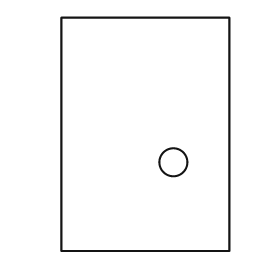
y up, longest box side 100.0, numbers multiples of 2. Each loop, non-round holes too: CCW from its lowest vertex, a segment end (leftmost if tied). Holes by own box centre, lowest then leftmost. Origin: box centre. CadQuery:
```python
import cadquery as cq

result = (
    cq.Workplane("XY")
    .moveTo(-36.0, -50.0)
    .lineTo(36.0, -50.0)
    .lineTo(36.0, 50.0)
    .lineTo(-36.0, 50.0)
    .close()
    .moveTo(12.0, -12.0)
    .circle(6.0)
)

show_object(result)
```